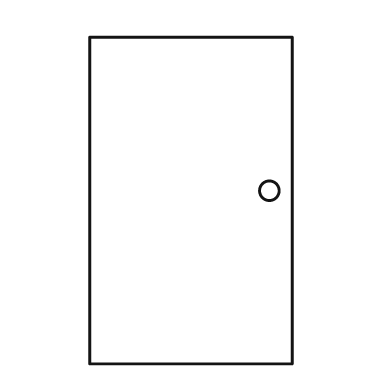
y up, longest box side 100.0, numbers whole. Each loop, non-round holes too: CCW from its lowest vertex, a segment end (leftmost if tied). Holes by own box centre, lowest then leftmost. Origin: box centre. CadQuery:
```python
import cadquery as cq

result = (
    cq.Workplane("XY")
    .moveTo(-31.0, -50.0)
    .lineTo(31.0, -50.0)
    .lineTo(31.0, 50.0)
    .lineTo(-31.0, 50.0)
    .close()
    .moveTo(24.0, 3.0)
    .circle(3.0)
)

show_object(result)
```